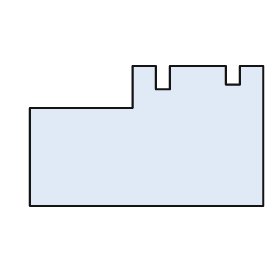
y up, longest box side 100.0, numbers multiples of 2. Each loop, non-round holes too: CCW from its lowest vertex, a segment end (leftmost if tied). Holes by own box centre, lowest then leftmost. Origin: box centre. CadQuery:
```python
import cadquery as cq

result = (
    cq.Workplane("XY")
    .moveTo(-50.0, -30.0)
    .lineTo(50.0, -30.0)
    .lineTo(50.0, 30.0)
    .lineTo(40.0, 30.0)
    .lineTo(40.0, 22.0)
    .lineTo(34.0, 22.0)
    .lineTo(34.0, 30.0)
    .lineTo(10.0, 30.0)
    .lineTo(10.0, 20.0)
    .lineTo(4.0, 20.0)
    .lineTo(4.0, 30.0)
    .lineTo(-6.0, 30.0)
    .lineTo(-6.0, 12.0)
    .lineTo(-50.0, 12.0)
    .close()
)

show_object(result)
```